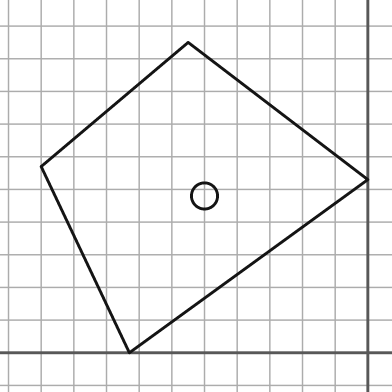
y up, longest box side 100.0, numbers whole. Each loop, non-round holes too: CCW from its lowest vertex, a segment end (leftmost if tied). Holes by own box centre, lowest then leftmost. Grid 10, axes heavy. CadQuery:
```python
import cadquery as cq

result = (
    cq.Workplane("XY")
    .moveTo(-73.0, 0.0)
    .lineTo(0.0, 53.0)
    .lineTo(-55.0, 95.0)
    .lineTo(-100.0, 57.0)
    .close()
    .moveTo(-50.0, 48.0)
    .circle(4.0)
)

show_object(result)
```